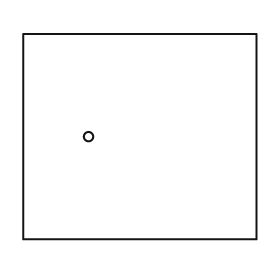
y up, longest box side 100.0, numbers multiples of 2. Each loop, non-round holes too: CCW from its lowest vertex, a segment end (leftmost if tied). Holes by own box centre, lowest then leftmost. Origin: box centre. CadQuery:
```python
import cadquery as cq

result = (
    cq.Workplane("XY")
    .moveTo(-50.0, -44.0)
    .lineTo(50.0, -44.0)
    .lineTo(50.0, 44.0)
    .lineTo(-50.0, 44.0)
    .close()
    .moveTo(-22.0, 0.0)
    .circle(2.0)
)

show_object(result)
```